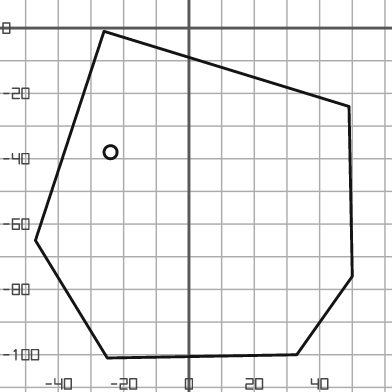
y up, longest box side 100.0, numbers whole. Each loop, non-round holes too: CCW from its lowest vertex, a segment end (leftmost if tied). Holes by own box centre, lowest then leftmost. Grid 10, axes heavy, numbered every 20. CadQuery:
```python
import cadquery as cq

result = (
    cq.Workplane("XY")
    .moveTo(-25.0, -101.0)
    .lineTo(33.0, -100.0)
    .lineTo(50.0, -76.0)
    .lineTo(49.0, -24.0)
    .lineTo(-26.0, -1.0)
    .lineTo(-47.0, -65.0)
    .close()
    .moveTo(-24.0, -38.0)
    .circle(2.0)
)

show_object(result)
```